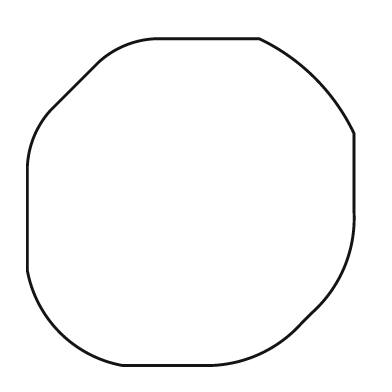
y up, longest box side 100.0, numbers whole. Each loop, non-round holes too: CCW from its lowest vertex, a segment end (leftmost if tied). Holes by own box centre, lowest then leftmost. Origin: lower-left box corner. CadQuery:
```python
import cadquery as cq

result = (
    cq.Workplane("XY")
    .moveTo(29.0, 0.0)
    .lineTo(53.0, 0.0)
    .threePointArc((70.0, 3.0), (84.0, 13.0))
    .lineTo(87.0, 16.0)
    .threePointArc((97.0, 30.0), (100.0, 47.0))
    .lineTo(100.0, 71.0)
    .threePointArc((88.0, 88.0), (71.0, 100.0))
    .lineTo(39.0, 100.0)
    .threePointArc((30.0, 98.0), (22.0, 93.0))
    .lineTo(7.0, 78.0)
    .threePointArc((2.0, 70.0), (0.0, 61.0))
    .lineTo(0.0, 29.0)
    .threePointArc((10.0, 10.0), (29.0, 0.0))
    .close()
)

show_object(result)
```